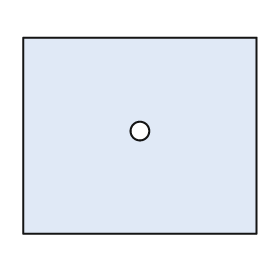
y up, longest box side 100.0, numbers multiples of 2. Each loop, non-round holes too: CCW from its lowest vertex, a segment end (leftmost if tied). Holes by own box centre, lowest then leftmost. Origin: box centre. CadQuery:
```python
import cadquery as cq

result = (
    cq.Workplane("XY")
    .moveTo(-50.0, -42.0)
    .lineTo(50.0, -42.0)
    .lineTo(50.0, 42.0)
    .lineTo(-50.0, 42.0)
    .close()
    .moveTo(0.0, 2.0)
    .circle(4.0)
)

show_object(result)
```